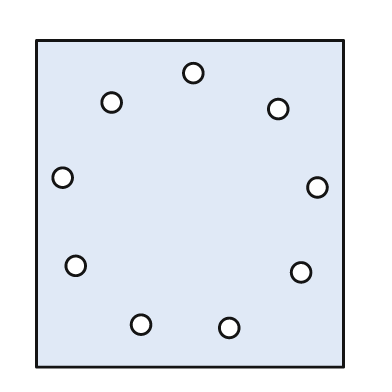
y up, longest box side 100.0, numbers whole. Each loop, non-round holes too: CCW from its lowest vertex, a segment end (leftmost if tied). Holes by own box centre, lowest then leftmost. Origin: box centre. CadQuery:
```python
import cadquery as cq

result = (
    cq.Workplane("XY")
    .moveTo(-47.0, -50.0)
    .lineTo(47.0, -50.0)
    .lineTo(47.0, 50.0)
    .lineTo(-47.0, 50.0)
    .close()
    .moveTo(12.0, -38.0)
    .circle(3.0)
    .moveTo(-15.0, -37.0)
    .circle(3.0)
    .moveTo(34.0, -21.0)
    .circle(3.0)
    .moveTo(-35.0, -19.0)
    .circle(3.0)
    .moveTo(39.0, 5.0)
    .circle(3.0)
    .moveTo(-39.0, 8.0)
    .circle(3.0)
    .moveTo(27.0, 29.0)
    .circle(3.0)
    .moveTo(-24.0, 31.0)
    .circle(3.0)
    .moveTo(1.0, 40.0)
    .circle(3.0)
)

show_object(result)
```